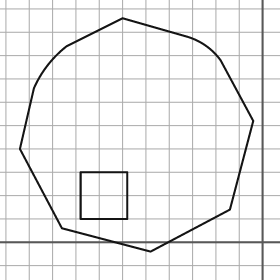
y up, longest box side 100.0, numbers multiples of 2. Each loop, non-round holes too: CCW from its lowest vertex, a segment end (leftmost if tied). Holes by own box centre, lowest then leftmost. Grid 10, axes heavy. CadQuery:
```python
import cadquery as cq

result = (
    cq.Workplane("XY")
    .moveTo(-48.0, -4.0)
    .lineTo(-14.0, 14.0)
    .lineTo(-4.0, 52.0)
    .lineTo(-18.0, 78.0)
    .threePointArc((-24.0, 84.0), (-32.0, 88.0))
    .lineTo(-60.0, 96.0)
    .lineTo(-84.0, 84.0)
    .threePointArc((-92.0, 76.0), (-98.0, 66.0))
    .lineTo(-104.0, 40.0)
    .lineTo(-86.0, 6.0)
    .close()
    .moveTo(-78.0, 10.0)
    .lineTo(-58.0, 10.0)
    .lineTo(-58.0, 30.0)
    .lineTo(-78.0, 30.0)
    .close()
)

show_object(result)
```